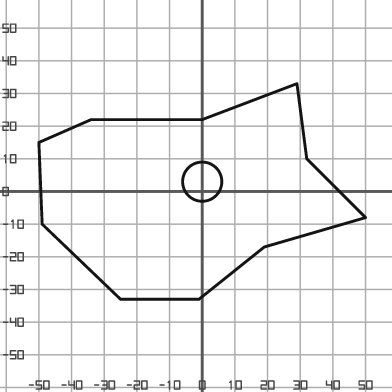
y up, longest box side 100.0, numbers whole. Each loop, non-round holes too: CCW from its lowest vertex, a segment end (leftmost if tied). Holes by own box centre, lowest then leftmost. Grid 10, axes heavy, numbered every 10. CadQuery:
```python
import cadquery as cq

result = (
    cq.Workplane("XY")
    .moveTo(-25.0, -33.0)
    .lineTo(-1.0, -33.0)
    .lineTo(19.0, -17.0)
    .lineTo(50.0, -8.0)
    .lineTo(32.0, 10.0)
    .lineTo(29.0, 33.0)
    .lineTo(0.0, 22.0)
    .lineTo(-34.0, 22.0)
    .lineTo(-50.0, 15.0)
    .lineTo(-49.0, -10.0)
    .close()
    .moveTo(0.0, 3.0)
    .circle(6.0)
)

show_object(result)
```